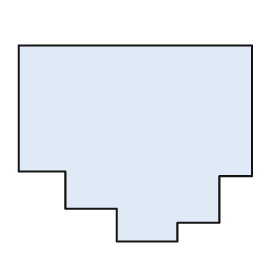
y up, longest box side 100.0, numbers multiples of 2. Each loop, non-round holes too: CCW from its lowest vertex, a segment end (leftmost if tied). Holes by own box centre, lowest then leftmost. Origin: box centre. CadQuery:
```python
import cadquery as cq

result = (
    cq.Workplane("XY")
    .moveTo(-8.0, -42.0)
    .lineTo(18.0, -42.0)
    .lineTo(18.0, -34.0)
    .lineTo(36.0, -34.0)
    .lineTo(36.0, -14.0)
    .lineTo(50.0, -14.0)
    .lineTo(50.0, 42.0)
    .lineTo(-50.0, 42.0)
    .lineTo(-50.0, -12.0)
    .lineTo(-30.0, -12.0)
    .lineTo(-30.0, -28.0)
    .lineTo(-8.0, -28.0)
    .close()
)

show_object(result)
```